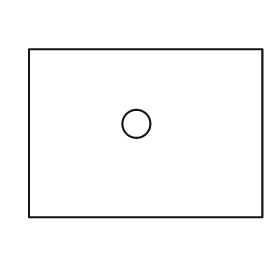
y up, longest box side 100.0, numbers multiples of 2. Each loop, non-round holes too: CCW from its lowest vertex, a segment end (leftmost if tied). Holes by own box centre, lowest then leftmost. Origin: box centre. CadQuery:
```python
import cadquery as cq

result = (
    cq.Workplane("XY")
    .moveTo(-50.0, -36.0)
    .lineTo(50.0, -36.0)
    .lineTo(50.0, 36.0)
    .lineTo(-50.0, 36.0)
    .close()
    .moveTo(-4.0, 4.0)
    .circle(6.0)
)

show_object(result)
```